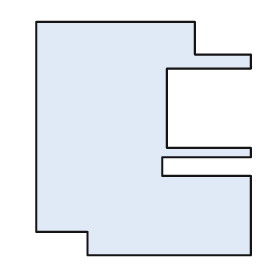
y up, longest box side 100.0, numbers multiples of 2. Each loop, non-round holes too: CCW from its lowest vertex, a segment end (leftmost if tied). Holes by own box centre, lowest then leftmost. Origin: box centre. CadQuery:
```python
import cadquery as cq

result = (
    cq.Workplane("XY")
    .moveTo(-24.0, -50.0)
    .lineTo(46.0, -50.0)
    .lineTo(46.0, -16.0)
    .lineTo(8.0, -16.0)
    .lineTo(8.0, -8.0)
    .lineTo(46.0, -8.0)
    .lineTo(46.0, -4.0)
    .lineTo(10.0, -4.0)
    .lineTo(10.0, 30.0)
    .lineTo(46.0, 30.0)
    .lineTo(46.0, 36.0)
    .lineTo(22.0, 36.0)
    .lineTo(22.0, 50.0)
    .lineTo(-46.0, 50.0)
    .lineTo(-46.0, -40.0)
    .lineTo(-24.0, -40.0)
    .close()
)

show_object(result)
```